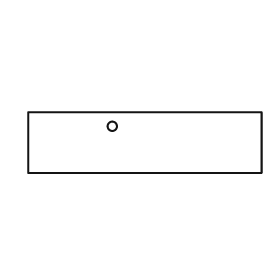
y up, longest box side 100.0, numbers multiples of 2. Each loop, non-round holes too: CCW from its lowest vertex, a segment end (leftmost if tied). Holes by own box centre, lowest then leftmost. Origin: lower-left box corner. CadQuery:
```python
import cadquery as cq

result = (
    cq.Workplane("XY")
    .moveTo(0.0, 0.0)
    .lineTo(100.0, 0.0)
    .lineTo(100.0, 26.0)
    .lineTo(0.0, 26.0)
    .close()
    .moveTo(36.0, 20.0)
    .circle(2.0)
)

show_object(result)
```